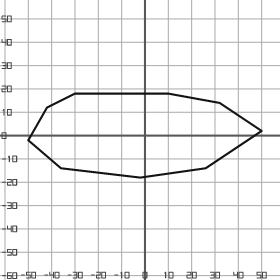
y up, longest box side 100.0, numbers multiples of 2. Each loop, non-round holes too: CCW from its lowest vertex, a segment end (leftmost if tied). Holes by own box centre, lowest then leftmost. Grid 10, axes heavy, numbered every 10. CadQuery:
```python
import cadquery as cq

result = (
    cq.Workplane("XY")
    .moveTo(-2.0, -18.0)
    .lineTo(26.0, -14.0)
    .lineTo(50.0, 2.0)
    .lineTo(32.0, 14.0)
    .lineTo(10.0, 18.0)
    .lineTo(-30.0, 18.0)
    .lineTo(-42.0, 12.0)
    .lineTo(-50.0, -2.0)
    .lineTo(-36.0, -14.0)
    .close()
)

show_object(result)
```